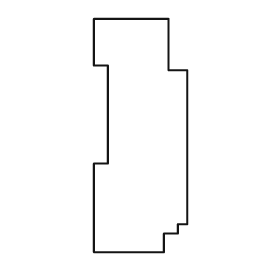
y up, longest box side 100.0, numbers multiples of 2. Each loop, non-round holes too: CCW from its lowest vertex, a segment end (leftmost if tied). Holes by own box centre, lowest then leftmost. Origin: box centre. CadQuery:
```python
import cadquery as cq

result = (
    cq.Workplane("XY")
    .moveTo(-20.0, -50.0)
    .lineTo(10.0, -50.0)
    .lineTo(10.0, -42.0)
    .lineTo(16.0, -42.0)
    .lineTo(16.0, -38.0)
    .lineTo(20.0, -38.0)
    .lineTo(20.0, 28.0)
    .lineTo(12.0, 28.0)
    .lineTo(12.0, 50.0)
    .lineTo(-20.0, 50.0)
    .lineTo(-20.0, 30.0)
    .lineTo(-14.0, 30.0)
    .lineTo(-14.0, -12.0)
    .lineTo(-20.0, -12.0)
    .close()
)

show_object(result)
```